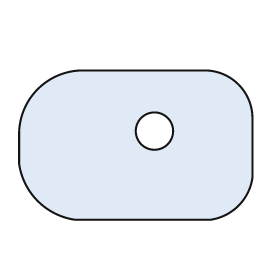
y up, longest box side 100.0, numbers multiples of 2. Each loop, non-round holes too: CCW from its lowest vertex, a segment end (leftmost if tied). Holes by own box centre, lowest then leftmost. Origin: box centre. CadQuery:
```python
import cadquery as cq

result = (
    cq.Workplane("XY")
    .moveTo(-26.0, -32.0)
    .lineTo(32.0, -32.0)
    .threePointArc((44.0, -26.0), (50.0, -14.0))
    .lineTo(50.0, 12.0)
    .threePointArc((44.0, 26.0), (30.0, 32.0))
    .lineTo(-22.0, 32.0)
    .threePointArc((-42.0, 24.0), (-50.0, 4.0))
    .lineTo(-50.0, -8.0)
    .threePointArc((-42.0, -24.0), (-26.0, -32.0))
    .close()
    .moveTo(8.0, 6.0)
    .circle(8.0)
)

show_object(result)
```